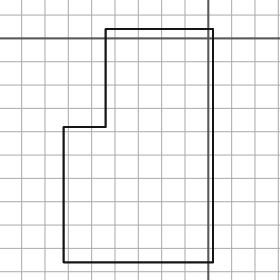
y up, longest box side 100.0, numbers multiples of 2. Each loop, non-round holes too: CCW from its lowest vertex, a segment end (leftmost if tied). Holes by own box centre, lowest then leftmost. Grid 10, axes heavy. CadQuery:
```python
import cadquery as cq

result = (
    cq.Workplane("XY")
    .moveTo(-62.0, -96.0)
    .lineTo(2.0, -96.0)
    .lineTo(2.0, 4.0)
    .lineTo(-44.0, 4.0)
    .lineTo(-44.0, -38.0)
    .lineTo(-62.0, -38.0)
    .close()
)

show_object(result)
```